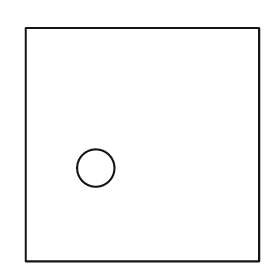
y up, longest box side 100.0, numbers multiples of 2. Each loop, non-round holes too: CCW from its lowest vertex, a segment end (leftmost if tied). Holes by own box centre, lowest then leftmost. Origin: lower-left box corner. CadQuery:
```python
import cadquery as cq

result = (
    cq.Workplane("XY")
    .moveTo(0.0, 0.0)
    .lineTo(100.0, 0.0)
    .lineTo(100.0, 100.0)
    .lineTo(0.0, 100.0)
    .close()
    .moveTo(30.0, 40.0)
    .circle(8.0)
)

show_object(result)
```